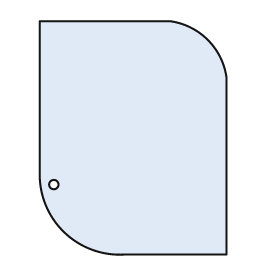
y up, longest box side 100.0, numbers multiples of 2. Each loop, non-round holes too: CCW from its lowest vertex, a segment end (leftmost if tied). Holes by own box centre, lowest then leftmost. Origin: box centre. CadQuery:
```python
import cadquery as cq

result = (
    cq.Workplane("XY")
    .moveTo(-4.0, -50.0)
    .lineTo(40.0, -50.0)
    .lineTo(40.0, 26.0)
    .threePointArc((32.0, 42.0), (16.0, 50.0))
    .lineTo(-40.0, 50.0)
    .lineTo(-40.0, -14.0)
    .threePointArc((-30.0, -40.0), (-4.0, -50.0))
    .close()
    .moveTo(-34.0, -20.0)
    .circle(2.0)
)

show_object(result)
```